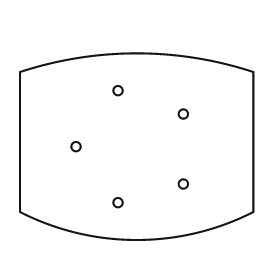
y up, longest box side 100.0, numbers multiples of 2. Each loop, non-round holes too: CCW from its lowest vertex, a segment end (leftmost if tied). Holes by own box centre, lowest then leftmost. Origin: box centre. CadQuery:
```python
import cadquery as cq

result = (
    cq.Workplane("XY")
    .moveTo(-50.0, -28.0)
    .threePointArc((0.0, -40.0), (50.0, -28.0))
    .lineTo(50.0, 32.0)
    .threePointArc((0.0, 40.0), (-50.0, 32.0))
    .close()
    .moveTo(-8.0, -24.0)
    .circle(2.0)
    .moveTo(20.0, -16.0)
    .circle(2.0)
    .moveTo(-26.0, 0.0)
    .circle(2.0)
    .moveTo(20.0, 14.0)
    .circle(2.0)
    .moveTo(-8.0, 24.0)
    .circle(2.0)
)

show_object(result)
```